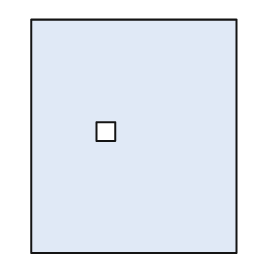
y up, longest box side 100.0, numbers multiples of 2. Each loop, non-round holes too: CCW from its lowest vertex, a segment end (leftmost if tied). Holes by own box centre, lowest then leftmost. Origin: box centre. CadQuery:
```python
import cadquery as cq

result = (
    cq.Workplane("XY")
    .moveTo(-44.0, -50.0)
    .lineTo(44.0, -50.0)
    .lineTo(44.0, 50.0)
    .lineTo(-44.0, 50.0)
    .close()
    .moveTo(-16.0, -2.0)
    .lineTo(-8.0, -2.0)
    .lineTo(-8.0, 6.0)
    .lineTo(-16.0, 6.0)
    .close()
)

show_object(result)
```